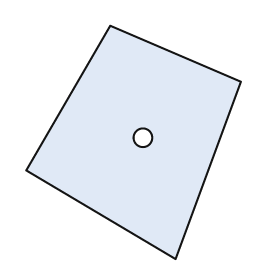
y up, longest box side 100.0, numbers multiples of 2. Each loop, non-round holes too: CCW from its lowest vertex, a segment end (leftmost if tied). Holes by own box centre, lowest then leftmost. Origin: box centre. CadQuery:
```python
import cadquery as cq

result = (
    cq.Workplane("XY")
    .moveTo(18.0, -50.0)
    .lineTo(46.0, 26.0)
    .lineTo(-10.0, 50.0)
    .lineTo(-46.0, -12.0)
    .close()
    .moveTo(4.0, 2.0)
    .circle(4.0)
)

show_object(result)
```